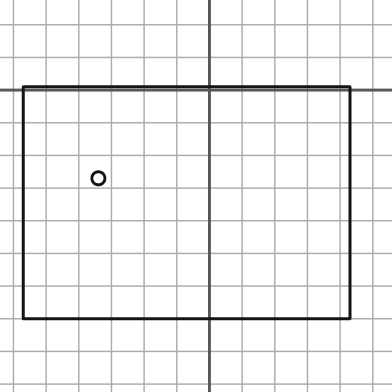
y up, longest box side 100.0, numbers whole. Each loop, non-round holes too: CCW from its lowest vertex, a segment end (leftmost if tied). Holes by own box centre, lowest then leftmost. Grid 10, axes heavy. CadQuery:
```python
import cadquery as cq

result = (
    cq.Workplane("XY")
    .moveTo(-57.0, -70.0)
    .lineTo(43.0, -70.0)
    .lineTo(43.0, 1.0)
    .lineTo(-57.0, 1.0)
    .close()
    .moveTo(-34.0, -27.0)
    .circle(2.0)
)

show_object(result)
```